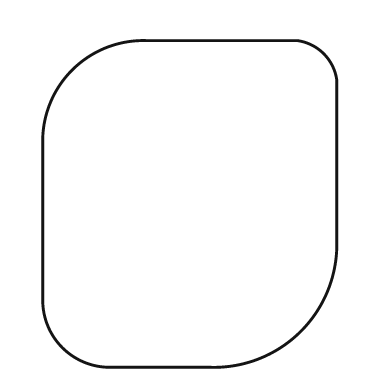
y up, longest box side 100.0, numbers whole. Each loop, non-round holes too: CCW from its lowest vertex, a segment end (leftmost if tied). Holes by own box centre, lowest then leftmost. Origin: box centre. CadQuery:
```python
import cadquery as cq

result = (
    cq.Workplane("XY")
    .moveTo(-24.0, -50.0)
    .lineTo(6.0, -50.0)
    .threePointArc((34.0, -39.0), (45.0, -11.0))
    .lineTo(45.0, 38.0)
    .threePointArc((41.0, 46.0), (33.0, 50.0))
    .lineTo(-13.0, 50.0)
    .threePointArc((-36.0, 41.0), (-45.0, 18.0))
    .lineTo(-45.0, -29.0)
    .threePointArc((-39.0, -44.0), (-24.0, -50.0))
    .close()
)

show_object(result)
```